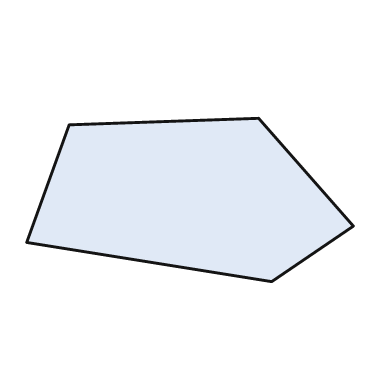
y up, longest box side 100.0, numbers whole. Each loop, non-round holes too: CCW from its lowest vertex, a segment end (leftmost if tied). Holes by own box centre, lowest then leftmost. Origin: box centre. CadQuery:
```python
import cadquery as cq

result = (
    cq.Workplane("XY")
    .moveTo(25.0, -25.0)
    .lineTo(50.0, -8.0)
    .lineTo(21.0, 25.0)
    .lineTo(-37.0, 23.0)
    .lineTo(-50.0, -13.0)
    .close()
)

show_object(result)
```